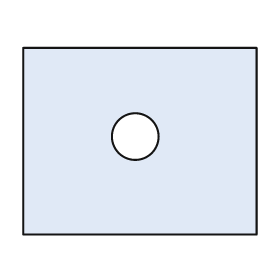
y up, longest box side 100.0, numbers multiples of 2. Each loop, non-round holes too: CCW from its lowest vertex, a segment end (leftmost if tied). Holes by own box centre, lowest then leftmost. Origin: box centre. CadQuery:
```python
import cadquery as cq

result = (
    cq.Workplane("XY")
    .moveTo(-50.0, -40.0)
    .lineTo(50.0, -40.0)
    .lineTo(50.0, 40.0)
    .lineTo(-50.0, 40.0)
    .close()
    .moveTo(-2.0, 2.0)
    .circle(10.0)
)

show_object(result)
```